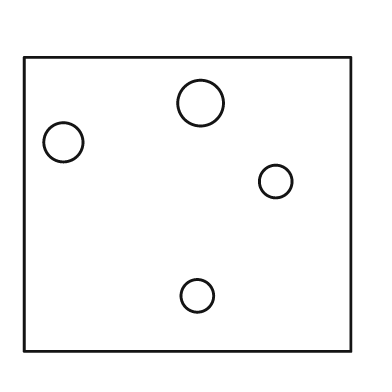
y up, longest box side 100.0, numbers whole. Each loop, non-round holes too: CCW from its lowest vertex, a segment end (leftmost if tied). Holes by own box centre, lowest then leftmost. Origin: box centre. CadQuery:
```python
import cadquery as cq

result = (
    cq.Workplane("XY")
    .moveTo(-50.0, -45.0)
    .lineTo(50.0, -45.0)
    .lineTo(50.0, 45.0)
    .lineTo(-50.0, 45.0)
    .close()
    .moveTo(3.0, -28.0)
    .circle(5.0)
    .moveTo(27.0, 7.0)
    .circle(5.0)
    .moveTo(-38.0, 19.0)
    .circle(6.0)
    .moveTo(4.0, 31.0)
    .circle(7.0)
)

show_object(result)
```